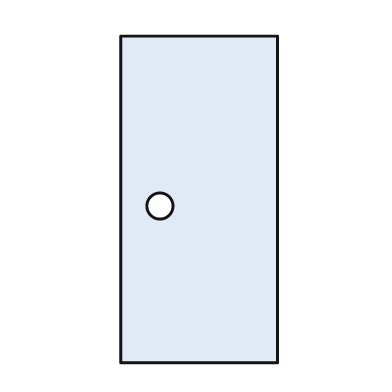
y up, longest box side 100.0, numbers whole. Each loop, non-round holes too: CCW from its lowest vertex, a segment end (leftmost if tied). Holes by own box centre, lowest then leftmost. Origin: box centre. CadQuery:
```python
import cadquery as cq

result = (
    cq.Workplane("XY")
    .moveTo(-24.0, -50.0)
    .lineTo(24.0, -50.0)
    .lineTo(24.0, 50.0)
    .lineTo(-24.0, 50.0)
    .close()
    .moveTo(-12.0, -2.0)
    .circle(4.0)
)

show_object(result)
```